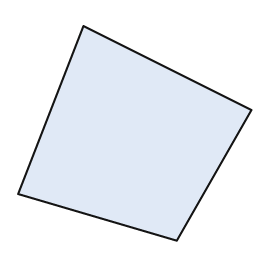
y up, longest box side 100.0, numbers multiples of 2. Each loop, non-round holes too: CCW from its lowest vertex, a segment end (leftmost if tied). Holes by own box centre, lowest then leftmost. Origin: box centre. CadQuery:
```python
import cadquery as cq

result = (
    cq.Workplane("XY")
    .moveTo(18.0, -46.0)
    .lineTo(50.0, 10.0)
    .lineTo(-22.0, 46.0)
    .lineTo(-50.0, -26.0)
    .close()
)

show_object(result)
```